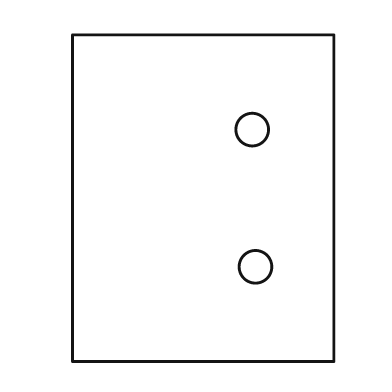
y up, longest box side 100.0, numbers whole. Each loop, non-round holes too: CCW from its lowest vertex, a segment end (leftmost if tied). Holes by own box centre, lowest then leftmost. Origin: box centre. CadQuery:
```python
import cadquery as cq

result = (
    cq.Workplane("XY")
    .moveTo(-40.0, -50.0)
    .lineTo(40.0, -50.0)
    .lineTo(40.0, 50.0)
    .lineTo(-40.0, 50.0)
    .close()
    .moveTo(16.0, -21.0)
    .circle(5.0)
    .moveTo(15.0, 21.0)
    .circle(5.0)
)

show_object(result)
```